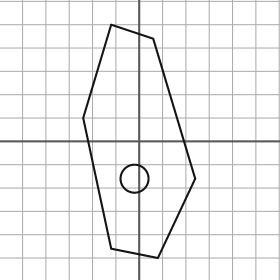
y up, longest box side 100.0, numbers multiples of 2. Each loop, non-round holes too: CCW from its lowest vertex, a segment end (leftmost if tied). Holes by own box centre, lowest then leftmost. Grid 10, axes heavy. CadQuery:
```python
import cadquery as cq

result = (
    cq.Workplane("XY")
    .moveTo(8.0, -50.0)
    .lineTo(24.0, -16.0)
    .lineTo(6.0, 44.0)
    .lineTo(-12.0, 50.0)
    .lineTo(-24.0, 10.0)
    .lineTo(-12.0, -46.0)
    .close()
    .moveTo(-2.0, -16.0)
    .circle(6.0)
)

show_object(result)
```